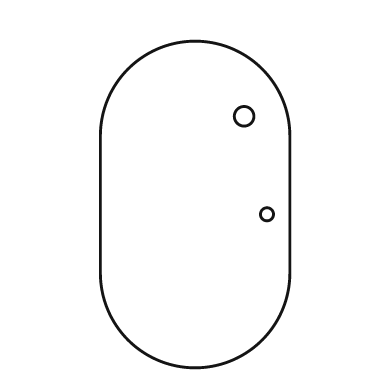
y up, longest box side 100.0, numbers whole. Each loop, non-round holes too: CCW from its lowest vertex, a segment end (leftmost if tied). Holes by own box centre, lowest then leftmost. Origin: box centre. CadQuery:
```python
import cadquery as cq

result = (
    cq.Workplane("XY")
    .moveTo(-29.0, -21.0)
    .threePointArc((0.0, -50.0), (29.0, -21.0))
    .lineTo(29.0, 21.0)
    .threePointArc((0.0, 50.0), (-29.0, 21.0))
    .close()
    .moveTo(22.0, -3.0)
    .circle(2.0)
    .moveTo(15.0, 27.0)
    .circle(3.0)
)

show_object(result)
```